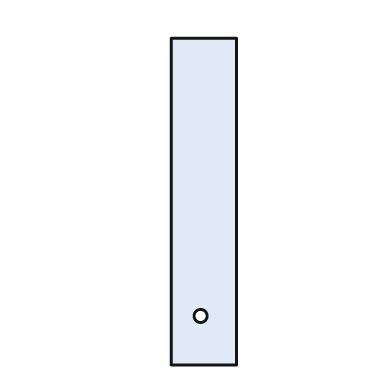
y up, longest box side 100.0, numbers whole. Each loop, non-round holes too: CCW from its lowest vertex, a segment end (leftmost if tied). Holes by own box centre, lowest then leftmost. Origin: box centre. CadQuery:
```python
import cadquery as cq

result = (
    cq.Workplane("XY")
    .moveTo(-10.0, -50.0)
    .lineTo(10.0, -50.0)
    .lineTo(10.0, 50.0)
    .lineTo(-10.0, 50.0)
    .close()
    .moveTo(-1.0, -35.0)
    .circle(2.0)
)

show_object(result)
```